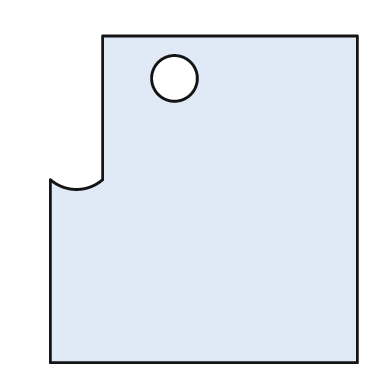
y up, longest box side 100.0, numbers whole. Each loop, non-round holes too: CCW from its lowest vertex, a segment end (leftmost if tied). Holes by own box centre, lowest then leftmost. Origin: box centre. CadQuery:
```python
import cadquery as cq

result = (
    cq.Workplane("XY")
    .moveTo(-47.0, -50.0)
    .lineTo(47.0, -50.0)
    .lineTo(47.0, 50.0)
    .lineTo(-31.0, 50.0)
    .lineTo(-31.0, 6.0)
    .threePointArc((-39.0, 3.0), (-47.0, 6.0))
    .close()
    .moveTo(-9.0, 37.0)
    .circle(7.0)
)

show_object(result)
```